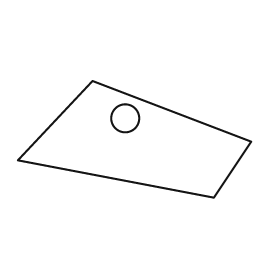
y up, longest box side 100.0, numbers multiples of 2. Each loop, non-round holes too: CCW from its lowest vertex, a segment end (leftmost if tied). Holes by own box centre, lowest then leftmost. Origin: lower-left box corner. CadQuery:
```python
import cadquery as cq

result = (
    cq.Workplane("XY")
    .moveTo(84.0, 0.0)
    .lineTo(100.0, 24.0)
    .lineTo(32.0, 50.0)
    .lineTo(0.0, 16.0)
    .close()
    .moveTo(46.0, 34.0)
    .circle(6.0)
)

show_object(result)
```